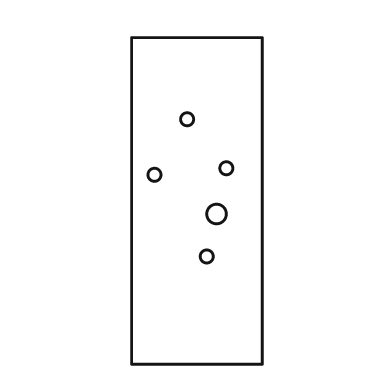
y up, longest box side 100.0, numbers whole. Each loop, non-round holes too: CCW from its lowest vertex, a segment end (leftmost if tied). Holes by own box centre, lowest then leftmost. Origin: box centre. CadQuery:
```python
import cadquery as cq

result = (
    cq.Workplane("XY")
    .moveTo(-20.0, -50.0)
    .lineTo(20.0, -50.0)
    .lineTo(20.0, 50.0)
    .lineTo(-20.0, 50.0)
    .close()
    .moveTo(3.0, -17.0)
    .circle(2.0)
    .moveTo(6.0, -4.0)
    .circle(3.0)
    .moveTo(-13.0, 8.0)
    .circle(2.0)
    .moveTo(9.0, 10.0)
    .circle(2.0)
    .moveTo(-3.0, 25.0)
    .circle(2.0)
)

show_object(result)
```